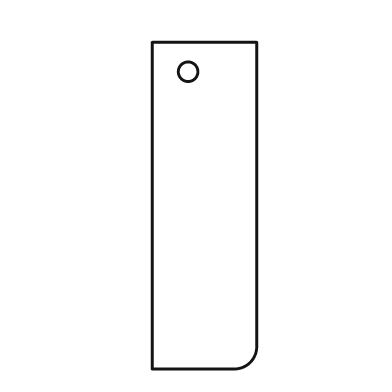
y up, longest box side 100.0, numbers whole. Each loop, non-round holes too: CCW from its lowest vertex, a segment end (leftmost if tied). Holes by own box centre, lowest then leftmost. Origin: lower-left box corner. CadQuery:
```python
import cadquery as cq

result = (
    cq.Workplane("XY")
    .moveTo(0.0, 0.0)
    .lineTo(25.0, 0.0)
    .threePointArc((30.0, 2.0), (32.0, 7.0))
    .lineTo(32.0, 100.0)
    .lineTo(0.0, 100.0)
    .close()
    .moveTo(11.0, 91.0)
    .circle(3.0)
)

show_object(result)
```